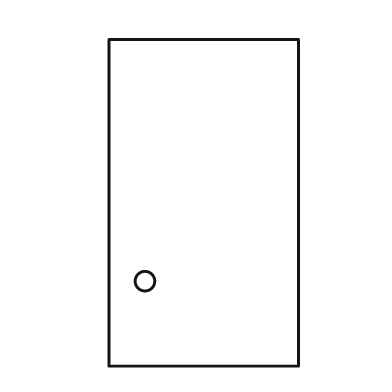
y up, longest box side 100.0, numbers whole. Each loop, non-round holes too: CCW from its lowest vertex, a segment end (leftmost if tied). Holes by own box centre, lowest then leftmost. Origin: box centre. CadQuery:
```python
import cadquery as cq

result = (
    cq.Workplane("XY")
    .moveTo(-29.0, -50.0)
    .lineTo(29.0, -50.0)
    .lineTo(29.0, 50.0)
    .lineTo(-29.0, 50.0)
    .close()
    .moveTo(-18.0, -24.0)
    .circle(3.0)
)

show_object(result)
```